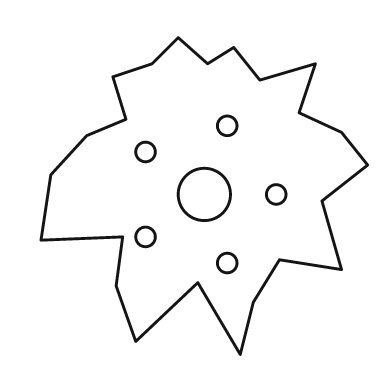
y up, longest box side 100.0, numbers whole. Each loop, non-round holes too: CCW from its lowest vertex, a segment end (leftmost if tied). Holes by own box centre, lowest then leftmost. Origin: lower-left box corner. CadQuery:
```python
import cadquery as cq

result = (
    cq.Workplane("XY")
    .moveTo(61.0, 0.0)
    .lineTo(65.0, 16.0)
    .lineTo(73.0, 29.0)
    .lineTo(92.0, 26.0)
    .lineTo(86.0, 47.0)
    .lineTo(100.0, 58.0)
    .lineTo(92.0, 68.0)
    .lineTo(79.0, 74.0)
    .lineTo(84.0, 89.0)
    .lineTo(67.0, 84.0)
    .lineTo(59.0, 94.0)
    .lineTo(51.0, 89.0)
    .lineTo(42.0, 97.0)
    .lineTo(34.0, 89.0)
    .lineTo(22.0, 85.0)
    .lineTo(26.0, 72.0)
    .lineTo(14.0, 67.0)
    .lineTo(3.0, 55.0)
    .lineTo(0.0, 35.0)
    .lineTo(25.0, 36.0)
    .lineTo(23.0, 21.0)
    .lineTo(29.0, 4.0)
    .lineTo(48.0, 22.0)
    .close()
    .moveTo(57.0, 28.0)
    .circle(3.0)
    .moveTo(32.0, 36.0)
    .circle(3.0)
    .moveTo(50.0, 49.0)
    .circle(8.0)
    .moveTo(72.0, 49.0)
    .circle(3.0)
    .moveTo(32.0, 62.0)
    .circle(3.0)
    .moveTo(57.0, 70.0)
    .circle(3.0)
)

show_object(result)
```